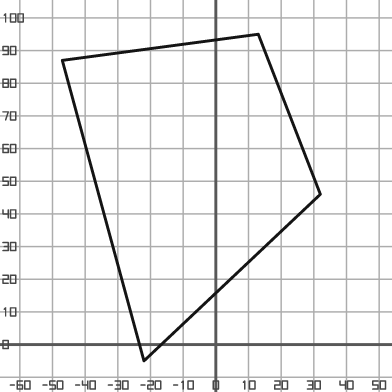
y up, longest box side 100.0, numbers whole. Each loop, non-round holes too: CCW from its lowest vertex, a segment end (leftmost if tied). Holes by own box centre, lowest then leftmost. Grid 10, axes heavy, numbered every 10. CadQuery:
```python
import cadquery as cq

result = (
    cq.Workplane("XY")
    .moveTo(-22.0, -5.0)
    .lineTo(32.0, 46.0)
    .lineTo(13.0, 95.0)
    .lineTo(-47.0, 87.0)
    .close()
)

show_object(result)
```